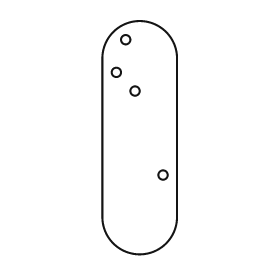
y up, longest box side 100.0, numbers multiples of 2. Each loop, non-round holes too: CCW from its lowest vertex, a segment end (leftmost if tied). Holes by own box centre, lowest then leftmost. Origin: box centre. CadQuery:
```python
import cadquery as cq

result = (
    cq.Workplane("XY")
    .moveTo(-16.0, -34.0)
    .threePointArc((0.0, -50.0), (16.0, -34.0))
    .lineTo(16.0, 34.0)
    .threePointArc((0.0, 50.0), (-16.0, 34.0))
    .close()
    .moveTo(10.0, -16.0)
    .circle(2.0)
    .moveTo(-2.0, 20.0)
    .circle(2.0)
    .moveTo(-10.0, 28.0)
    .circle(2.0)
    .moveTo(-6.0, 42.0)
    .circle(2.0)
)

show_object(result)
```